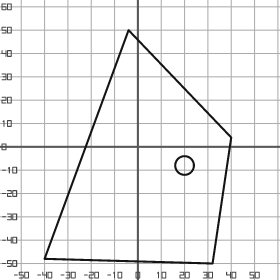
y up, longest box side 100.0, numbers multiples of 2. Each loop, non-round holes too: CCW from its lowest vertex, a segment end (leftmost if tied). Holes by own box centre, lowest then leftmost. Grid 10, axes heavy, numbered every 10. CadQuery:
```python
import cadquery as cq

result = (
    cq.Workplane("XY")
    .moveTo(32.0, -50.0)
    .lineTo(40.0, 4.0)
    .lineTo(-4.0, 50.0)
    .lineTo(-40.0, -48.0)
    .close()
    .moveTo(20.0, -8.0)
    .circle(4.0)
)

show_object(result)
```